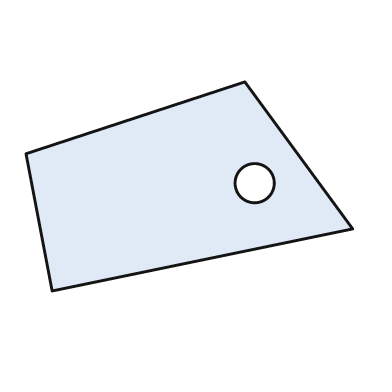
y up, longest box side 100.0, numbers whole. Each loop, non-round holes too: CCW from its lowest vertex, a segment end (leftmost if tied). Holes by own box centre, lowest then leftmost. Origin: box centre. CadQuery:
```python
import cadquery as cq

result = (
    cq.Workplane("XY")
    .moveTo(-42.0, -32.0)
    .lineTo(50.0, -13.0)
    .lineTo(17.0, 32.0)
    .lineTo(-50.0, 10.0)
    .close()
    .moveTo(20.0, 1.0)
    .circle(6.0)
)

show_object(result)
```